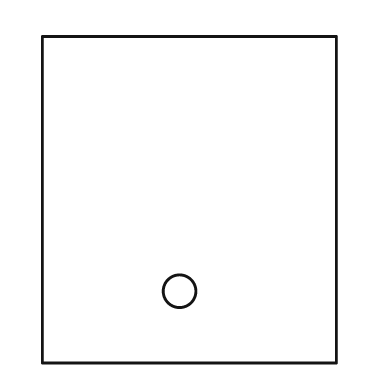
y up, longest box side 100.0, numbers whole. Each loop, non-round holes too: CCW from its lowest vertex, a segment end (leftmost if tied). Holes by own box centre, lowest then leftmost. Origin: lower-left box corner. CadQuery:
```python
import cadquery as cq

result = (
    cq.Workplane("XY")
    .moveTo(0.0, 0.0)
    .lineTo(90.0, 0.0)
    .lineTo(90.0, 100.0)
    .lineTo(0.0, 100.0)
    .close()
    .moveTo(42.0, 22.0)
    .circle(5.0)
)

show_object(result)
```